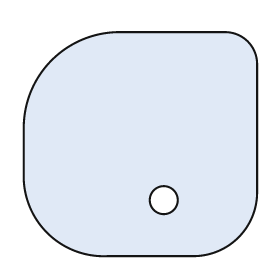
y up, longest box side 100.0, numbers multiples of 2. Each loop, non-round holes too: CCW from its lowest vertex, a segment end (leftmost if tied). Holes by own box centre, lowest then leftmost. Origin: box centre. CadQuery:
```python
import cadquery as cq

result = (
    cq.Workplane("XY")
    .moveTo(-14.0, -48.0)
    .lineTo(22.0, -48.0)
    .threePointArc((42.0, -40.0), (50.0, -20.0))
    .lineTo(50.0, 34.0)
    .threePointArc((46.0, 44.0), (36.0, 48.0))
    .lineTo(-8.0, 48.0)
    .threePointArc((-38.0, 36.0), (-50.0, 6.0))
    .lineTo(-50.0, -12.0)
    .threePointArc((-40.0, -38.0), (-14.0, -48.0))
    .close()
    .moveTo(10.0, -24.0)
    .circle(6.0)
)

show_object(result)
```